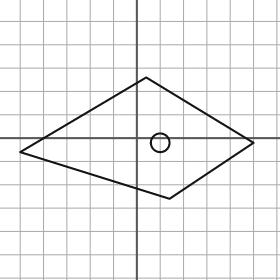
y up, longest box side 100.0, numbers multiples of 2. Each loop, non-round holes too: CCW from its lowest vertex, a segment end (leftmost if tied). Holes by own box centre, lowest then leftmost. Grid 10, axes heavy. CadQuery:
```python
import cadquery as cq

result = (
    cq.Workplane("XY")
    .moveTo(14.0, -26.0)
    .lineTo(50.0, -2.0)
    .lineTo(4.0, 26.0)
    .lineTo(-50.0, -6.0)
    .close()
    .moveTo(10.0, -2.0)
    .circle(4.0)
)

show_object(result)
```